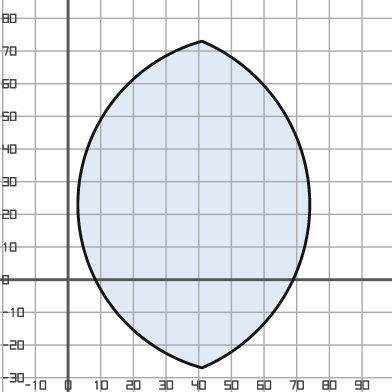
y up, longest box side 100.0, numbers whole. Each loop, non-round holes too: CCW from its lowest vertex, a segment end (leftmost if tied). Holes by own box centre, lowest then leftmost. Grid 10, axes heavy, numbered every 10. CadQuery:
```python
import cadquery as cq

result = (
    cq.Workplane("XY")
    .moveTo(41.0, -27.0)
    .threePointArc((74.0, 23.0), (41.0, 73.0))
    .threePointArc((3.0, 23.0), (41.0, -27.0))
    .close()
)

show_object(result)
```